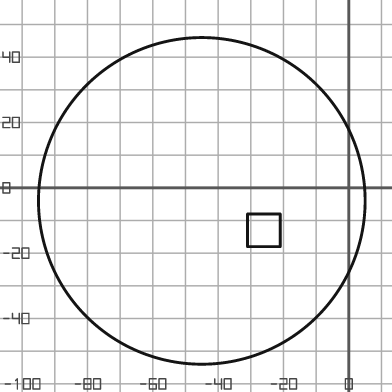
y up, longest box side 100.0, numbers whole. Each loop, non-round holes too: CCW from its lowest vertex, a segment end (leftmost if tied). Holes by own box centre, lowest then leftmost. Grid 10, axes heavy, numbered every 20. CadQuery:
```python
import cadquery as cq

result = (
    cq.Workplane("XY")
    .moveTo(-45.0, -4.0)
    .circle(50.0)
    .moveTo(-31.0, -18.0)
    .lineTo(-21.0, -18.0)
    .lineTo(-21.0, -8.0)
    .lineTo(-31.0, -8.0)
    .close()
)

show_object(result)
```